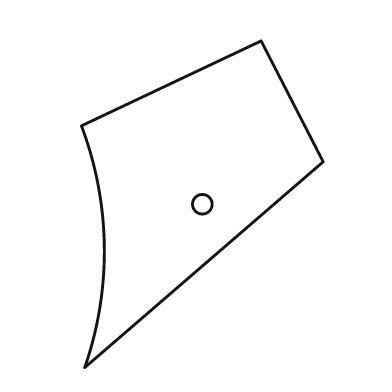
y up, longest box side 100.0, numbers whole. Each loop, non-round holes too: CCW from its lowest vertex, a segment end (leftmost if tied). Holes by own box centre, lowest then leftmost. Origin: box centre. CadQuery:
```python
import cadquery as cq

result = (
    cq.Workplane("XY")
    .moveTo(-36.0, -50.0)
    .lineTo(37.0, 13.0)
    .lineTo(18.0, 50.0)
    .lineTo(-37.0, 24.0)
    .threePointArc((-30.0, -13.0), (-36.0, -50.0))
    .close()
    .moveTo(0.0, 0.0)
    .circle(3.0)
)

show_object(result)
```